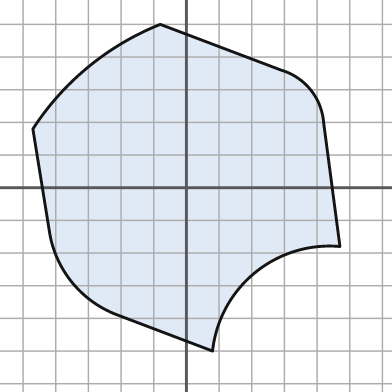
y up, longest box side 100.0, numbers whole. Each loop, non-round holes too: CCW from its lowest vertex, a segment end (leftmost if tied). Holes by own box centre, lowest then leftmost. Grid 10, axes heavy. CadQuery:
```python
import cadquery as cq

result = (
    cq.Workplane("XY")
    .moveTo(8.0, -50.0)
    .threePointArc((21.0, -26.0), (47.0, -18.0))
    .lineTo(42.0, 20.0)
    .threePointArc((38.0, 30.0), (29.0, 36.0))
    .lineTo(-8.0, 50.0)
    .threePointArc((-30.0, 37.0), (-47.0, 18.0))
    .lineTo(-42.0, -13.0)
    .threePointArc((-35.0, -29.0), (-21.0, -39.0))
    .close()
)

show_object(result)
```